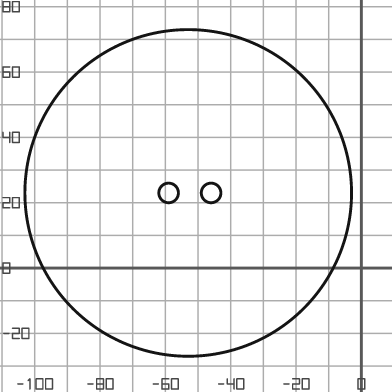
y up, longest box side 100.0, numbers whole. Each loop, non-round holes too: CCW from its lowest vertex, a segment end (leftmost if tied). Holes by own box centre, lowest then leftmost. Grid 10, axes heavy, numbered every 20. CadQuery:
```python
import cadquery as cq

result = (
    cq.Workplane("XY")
    .moveTo(-53.0, 23.0)
    .circle(50.0)
    .moveTo(-59.0, 23.0)
    .circle(3.0)
    .moveTo(-46.0, 23.0)
    .circle(3.0)
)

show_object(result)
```